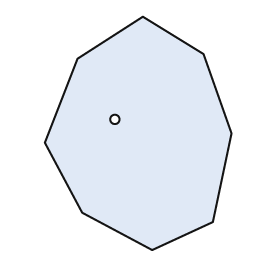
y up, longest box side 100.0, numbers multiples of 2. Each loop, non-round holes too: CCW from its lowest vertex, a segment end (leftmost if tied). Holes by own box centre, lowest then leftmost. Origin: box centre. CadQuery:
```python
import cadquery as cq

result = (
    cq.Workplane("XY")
    .moveTo(6.0, -50.0)
    .lineTo(32.0, -38.0)
    .lineTo(40.0, 0.0)
    .lineTo(28.0, 34.0)
    .lineTo(2.0, 50.0)
    .lineTo(-26.0, 32.0)
    .lineTo(-40.0, -4.0)
    .lineTo(-24.0, -34.0)
    .close()
    .moveTo(-10.0, 6.0)
    .circle(2.0)
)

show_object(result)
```